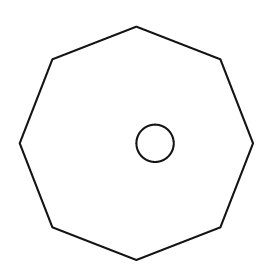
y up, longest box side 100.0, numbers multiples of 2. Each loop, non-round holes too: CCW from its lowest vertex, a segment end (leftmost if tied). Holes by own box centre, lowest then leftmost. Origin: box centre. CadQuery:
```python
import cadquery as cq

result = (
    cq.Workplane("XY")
    .moveTo(0.0, -50.0)
    .lineTo(36.0, -36.0)
    .lineTo(50.0, 0.0)
    .lineTo(36.0, 36.0)
    .lineTo(0.0, 50.0)
    .lineTo(-36.0, 36.0)
    .lineTo(-50.0, 0.0)
    .lineTo(-36.0, -36.0)
    .close()
    .moveTo(8.0, 0.0)
    .circle(8.0)
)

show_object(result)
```